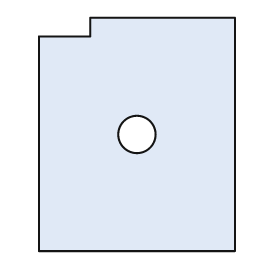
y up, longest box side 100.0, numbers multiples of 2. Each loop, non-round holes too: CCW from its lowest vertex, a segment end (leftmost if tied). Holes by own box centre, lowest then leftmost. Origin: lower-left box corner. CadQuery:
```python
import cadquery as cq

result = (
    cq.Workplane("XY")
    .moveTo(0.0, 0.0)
    .lineTo(84.0, 0.0)
    .lineTo(84.0, 100.0)
    .lineTo(22.0, 100.0)
    .lineTo(22.0, 92.0)
    .lineTo(0.0, 92.0)
    .close()
    .moveTo(42.0, 50.0)
    .circle(8.0)
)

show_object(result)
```